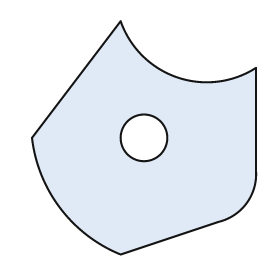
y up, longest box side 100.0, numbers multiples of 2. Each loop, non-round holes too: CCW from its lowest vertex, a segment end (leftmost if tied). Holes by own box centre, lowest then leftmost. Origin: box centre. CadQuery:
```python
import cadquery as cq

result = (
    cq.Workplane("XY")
    .moveTo(-10.0, -50.0)
    .lineTo(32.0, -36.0)
    .threePointArc((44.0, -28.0), (48.0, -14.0))
    .lineTo(48.0, 30.0)
    .threePointArc((14.0, 26.0), (-10.0, 50.0))
    .lineTo(-48.0, 0.0)
    .threePointArc((-36.0, -30.0), (-10.0, -50.0))
    .close()
    .moveTo(0.0, 0.0)
    .circle(10.0)
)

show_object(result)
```